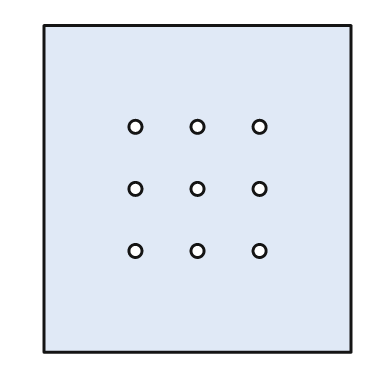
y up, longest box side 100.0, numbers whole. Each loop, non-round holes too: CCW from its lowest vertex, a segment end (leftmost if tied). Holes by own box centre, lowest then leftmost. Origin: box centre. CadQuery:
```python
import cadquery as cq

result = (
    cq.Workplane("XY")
    .moveTo(-47.0, -50.0)
    .lineTo(47.0, -50.0)
    .lineTo(47.0, 50.0)
    .lineTo(-47.0, 50.0)
    .close()
    .moveTo(-19.0, -19.0)
    .circle(2.0)
    .moveTo(0.0, -19.0)
    .circle(2.0)
    .moveTo(19.0, -19.0)
    .circle(2.0)
    .moveTo(-19.0, 0.0)
    .circle(2.0)
    .moveTo(0.0, 0.0)
    .circle(2.0)
    .moveTo(19.0, 0.0)
    .circle(2.0)
    .moveTo(-19.0, 19.0)
    .circle(2.0)
    .moveTo(0.0, 19.0)
    .circle(2.0)
    .moveTo(19.0, 19.0)
    .circle(2.0)
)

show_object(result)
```